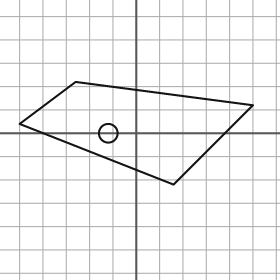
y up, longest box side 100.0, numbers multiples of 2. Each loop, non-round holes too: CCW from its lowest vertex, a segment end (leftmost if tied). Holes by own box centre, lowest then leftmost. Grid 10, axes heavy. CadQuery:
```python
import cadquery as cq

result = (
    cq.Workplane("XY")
    .moveTo(16.0, -22.0)
    .lineTo(50.0, 12.0)
    .lineTo(-26.0, 22.0)
    .lineTo(-50.0, 4.0)
    .close()
    .moveTo(-12.0, 0.0)
    .circle(4.0)
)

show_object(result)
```